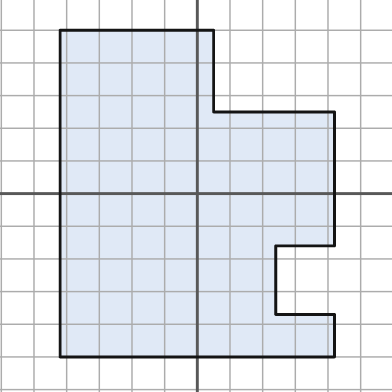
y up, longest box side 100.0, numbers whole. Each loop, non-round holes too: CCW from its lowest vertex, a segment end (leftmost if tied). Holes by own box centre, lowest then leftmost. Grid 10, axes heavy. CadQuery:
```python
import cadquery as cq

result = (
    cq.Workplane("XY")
    .moveTo(-42.0, -50.0)
    .lineTo(42.0, -50.0)
    .lineTo(42.0, -37.0)
    .lineTo(24.0, -37.0)
    .lineTo(24.0, -16.0)
    .lineTo(42.0, -16.0)
    .lineTo(42.0, 25.0)
    .lineTo(5.0, 25.0)
    .lineTo(5.0, 50.0)
    .lineTo(-42.0, 50.0)
    .close()
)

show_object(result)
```